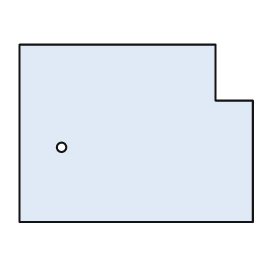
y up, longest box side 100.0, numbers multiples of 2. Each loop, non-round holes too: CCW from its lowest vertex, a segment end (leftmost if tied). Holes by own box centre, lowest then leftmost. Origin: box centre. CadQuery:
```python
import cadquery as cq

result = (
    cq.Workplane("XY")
    .moveTo(-50.0, -38.0)
    .lineTo(50.0, -38.0)
    .lineTo(50.0, 14.0)
    .lineTo(34.0, 14.0)
    .lineTo(34.0, 38.0)
    .lineTo(-50.0, 38.0)
    .close()
    .moveTo(-32.0, -6.0)
    .circle(2.0)
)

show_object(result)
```